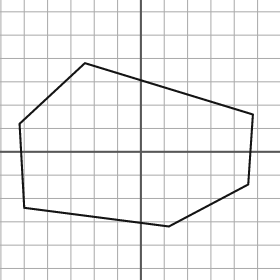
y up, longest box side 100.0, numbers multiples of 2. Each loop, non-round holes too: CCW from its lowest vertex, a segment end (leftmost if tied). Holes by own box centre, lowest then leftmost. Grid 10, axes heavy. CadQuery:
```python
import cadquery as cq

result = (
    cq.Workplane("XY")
    .moveTo(12.0, -32.0)
    .lineTo(46.0, -14.0)
    .lineTo(48.0, 16.0)
    .lineTo(-24.0, 38.0)
    .lineTo(-52.0, 12.0)
    .lineTo(-50.0, -24.0)
    .close()
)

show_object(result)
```